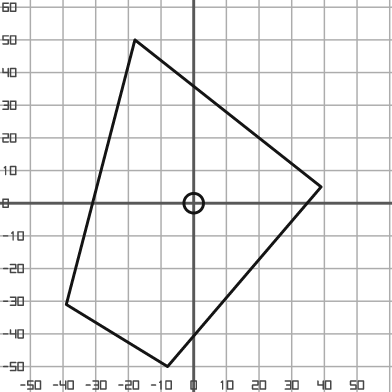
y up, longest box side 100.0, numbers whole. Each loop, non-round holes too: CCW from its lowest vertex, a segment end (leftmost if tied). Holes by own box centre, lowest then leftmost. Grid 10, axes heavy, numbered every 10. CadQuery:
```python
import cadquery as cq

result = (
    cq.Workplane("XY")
    .moveTo(-8.0, -50.0)
    .lineTo(39.0, 5.0)
    .lineTo(-18.0, 50.0)
    .lineTo(-39.0, -31.0)
    .close()
    .moveTo(0.0, 0.0)
    .circle(3.0)
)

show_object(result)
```